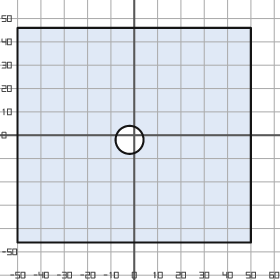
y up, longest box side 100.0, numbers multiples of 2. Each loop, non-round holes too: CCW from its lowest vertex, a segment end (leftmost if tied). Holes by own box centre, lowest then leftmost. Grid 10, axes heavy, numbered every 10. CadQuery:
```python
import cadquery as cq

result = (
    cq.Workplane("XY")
    .moveTo(-50.0, -46.0)
    .lineTo(50.0, -46.0)
    .lineTo(50.0, 46.0)
    .lineTo(-50.0, 46.0)
    .close()
    .moveTo(-2.0, -2.0)
    .circle(6.0)
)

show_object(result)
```